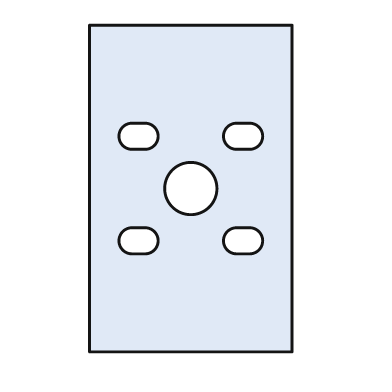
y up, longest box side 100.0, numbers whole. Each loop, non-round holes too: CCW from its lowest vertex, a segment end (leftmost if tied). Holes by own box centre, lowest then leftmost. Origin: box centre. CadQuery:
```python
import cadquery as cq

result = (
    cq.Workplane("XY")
    .moveTo(-31.0, -50.0)
    .lineTo(31.0, -50.0)
    .lineTo(31.0, 50.0)
    .lineTo(-31.0, 50.0)
    .close()
    .moveTo(-18.0, -20.0)
    .lineTo(-14.0, -20.0)
    .threePointArc((-10.0, -16.0), (-14.0, -12.0))
    .lineTo(-18.0, -12.0)
    .threePointArc((-22.0, -16.0), (-18.0, -20.0))
    .close()
    .moveTo(14.0, -20.0)
    .lineTo(18.0, -20.0)
    .threePointArc((22.0, -16.0), (18.0, -12.0))
    .lineTo(14.0, -12.0)
    .threePointArc((10.0, -16.0), (14.0, -20.0))
    .close()
    .moveTo(0.0, 0.0)
    .circle(8.0)
    .moveTo(-18.0, 12.0)
    .lineTo(-14.0, 12.0)
    .threePointArc((-10.0, 16.0), (-14.0, 20.0))
    .lineTo(-18.0, 20.0)
    .threePointArc((-22.0, 16.0), (-18.0, 12.0))
    .close()
    .moveTo(14.0, 12.0)
    .lineTo(18.0, 12.0)
    .threePointArc((22.0, 16.0), (18.0, 20.0))
    .lineTo(14.0, 20.0)
    .threePointArc((10.0, 16.0), (14.0, 12.0))
    .close()
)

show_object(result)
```